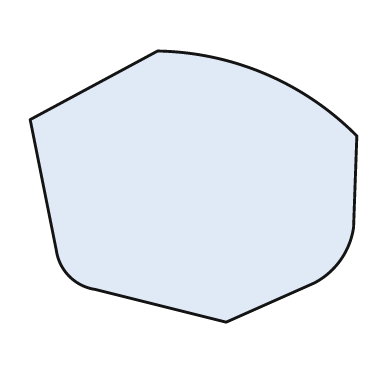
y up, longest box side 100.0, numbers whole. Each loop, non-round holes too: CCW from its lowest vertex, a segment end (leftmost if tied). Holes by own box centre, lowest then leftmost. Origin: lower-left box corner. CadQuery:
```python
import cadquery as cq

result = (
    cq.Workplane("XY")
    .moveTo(60.0, 0.0)
    .lineTo(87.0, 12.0)
    .threePointArc((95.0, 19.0), (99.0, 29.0))
    .lineTo(100.0, 57.0)
    .threePointArc((72.0, 76.0), (39.0, 83.0))
    .lineTo(0.0, 62.0)
    .lineTo(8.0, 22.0)
    .threePointArc((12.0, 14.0), (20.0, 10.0))
    .close()
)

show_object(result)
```